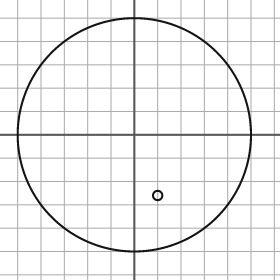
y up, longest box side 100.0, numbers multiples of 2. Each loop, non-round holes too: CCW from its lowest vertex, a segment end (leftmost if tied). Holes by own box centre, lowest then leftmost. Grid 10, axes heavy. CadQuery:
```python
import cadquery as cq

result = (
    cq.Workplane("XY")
    .moveTo(0.0, 0.0)
    .circle(50.0)
    .moveTo(10.0, -26.0)
    .circle(2.0)
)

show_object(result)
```